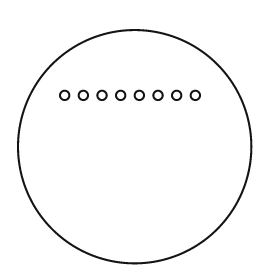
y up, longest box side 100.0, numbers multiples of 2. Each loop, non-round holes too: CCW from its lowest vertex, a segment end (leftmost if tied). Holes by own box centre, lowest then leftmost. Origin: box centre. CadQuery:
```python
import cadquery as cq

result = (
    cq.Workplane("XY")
    .moveTo(0.0, 0.0)
    .circle(50.0)
    .moveTo(-30.0, 22.0)
    .circle(2.0)
    .moveTo(-22.0, 22.0)
    .circle(2.0)
    .moveTo(-14.0, 22.0)
    .circle(2.0)
    .moveTo(-6.0, 22.0)
    .circle(2.0)
    .moveTo(2.0, 22.0)
    .circle(2.0)
    .moveTo(10.0, 22.0)
    .circle(2.0)
    .moveTo(18.0, 22.0)
    .circle(2.0)
    .moveTo(26.0, 22.0)
    .circle(2.0)
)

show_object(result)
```